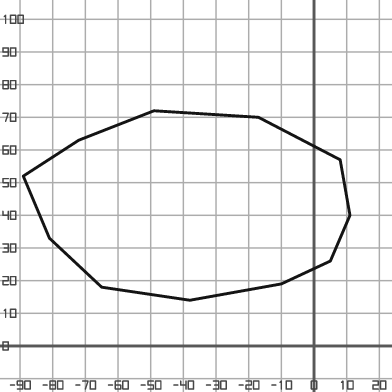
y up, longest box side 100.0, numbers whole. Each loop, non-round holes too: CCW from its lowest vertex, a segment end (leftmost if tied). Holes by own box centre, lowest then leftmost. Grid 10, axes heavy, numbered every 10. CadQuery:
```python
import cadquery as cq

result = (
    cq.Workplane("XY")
    .moveTo(-38.0, 14.0)
    .lineTo(-10.0, 19.0)
    .lineTo(5.0, 26.0)
    .lineTo(11.0, 40.0)
    .lineTo(8.0, 57.0)
    .lineTo(-17.0, 70.0)
    .lineTo(-49.0, 72.0)
    .lineTo(-72.0, 63.0)
    .lineTo(-89.0, 52.0)
    .lineTo(-81.0, 33.0)
    .lineTo(-65.0, 18.0)
    .close()
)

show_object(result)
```